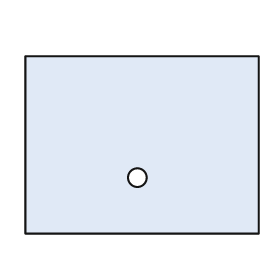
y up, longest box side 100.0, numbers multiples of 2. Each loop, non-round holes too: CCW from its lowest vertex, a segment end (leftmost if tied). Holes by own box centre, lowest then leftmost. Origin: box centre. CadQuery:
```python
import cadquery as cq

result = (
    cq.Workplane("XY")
    .moveTo(-50.0, -38.0)
    .lineTo(50.0, -38.0)
    .lineTo(50.0, 38.0)
    .lineTo(-50.0, 38.0)
    .close()
    .moveTo(-2.0, -14.0)
    .circle(4.0)
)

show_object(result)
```